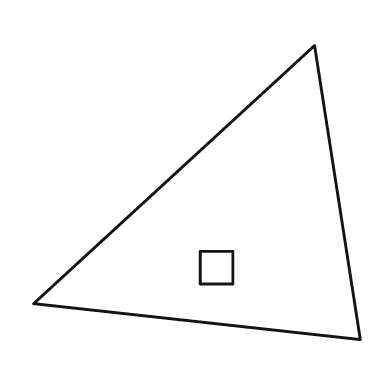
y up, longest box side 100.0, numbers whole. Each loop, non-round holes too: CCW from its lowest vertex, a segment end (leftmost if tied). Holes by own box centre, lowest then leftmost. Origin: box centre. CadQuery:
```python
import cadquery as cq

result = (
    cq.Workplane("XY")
    .moveTo(50.0, -45.0)
    .lineTo(36.0, 45.0)
    .lineTo(-50.0, -34.0)
    .close()
    .moveTo(1.0, -28.0)
    .lineTo(11.0, -28.0)
    .lineTo(11.0, -18.0)
    .lineTo(1.0, -18.0)
    .close()
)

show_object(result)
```